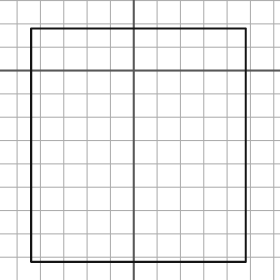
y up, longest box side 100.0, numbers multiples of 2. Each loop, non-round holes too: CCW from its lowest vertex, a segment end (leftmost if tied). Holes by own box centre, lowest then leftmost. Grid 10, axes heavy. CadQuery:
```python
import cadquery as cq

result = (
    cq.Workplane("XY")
    .moveTo(-44.0, -82.0)
    .lineTo(48.0, -82.0)
    .lineTo(48.0, 18.0)
    .lineTo(-44.0, 18.0)
    .close()
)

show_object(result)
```